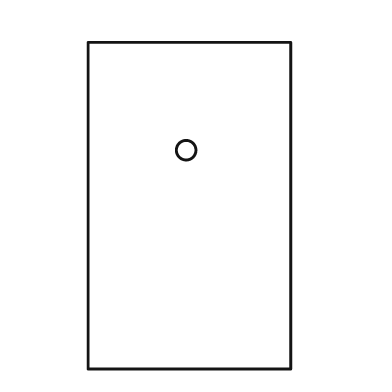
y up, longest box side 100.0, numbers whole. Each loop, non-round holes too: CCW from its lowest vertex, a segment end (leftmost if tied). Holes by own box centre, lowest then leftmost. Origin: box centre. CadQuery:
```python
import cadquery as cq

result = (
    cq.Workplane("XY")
    .moveTo(-31.0, -50.0)
    .lineTo(31.0, -50.0)
    .lineTo(31.0, 50.0)
    .lineTo(-31.0, 50.0)
    .close()
    .moveTo(-1.0, 17.0)
    .circle(3.0)
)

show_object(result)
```